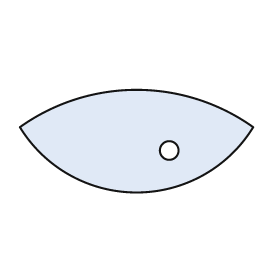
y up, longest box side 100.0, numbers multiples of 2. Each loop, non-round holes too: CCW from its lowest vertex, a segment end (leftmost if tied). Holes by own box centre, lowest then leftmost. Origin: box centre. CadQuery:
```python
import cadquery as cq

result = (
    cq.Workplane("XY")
    .moveTo(-50.0, 6.0)
    .threePointArc((0.0, -22.0), (50.0, 6.0))
    .threePointArc((0.0, 22.0), (-50.0, 6.0))
    .close()
    .moveTo(14.0, -4.0)
    .circle(4.0)
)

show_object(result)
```